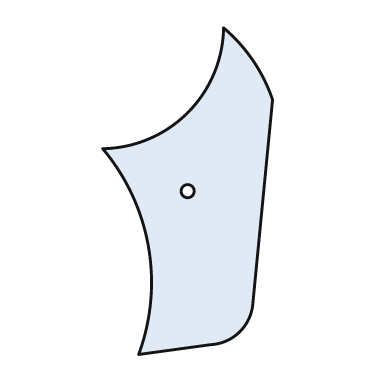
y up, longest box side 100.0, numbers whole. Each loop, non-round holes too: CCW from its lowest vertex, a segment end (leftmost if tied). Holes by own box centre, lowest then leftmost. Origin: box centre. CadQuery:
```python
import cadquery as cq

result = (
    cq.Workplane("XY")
    .moveTo(-15.0, -50.0)
    .lineTo(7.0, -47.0)
    .threePointArc((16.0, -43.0), (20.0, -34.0))
    .lineTo(26.0, 28.0)
    .threePointArc((20.0, 40.0), (11.0, 50.0))
    .threePointArc((0.0, 24.0), (-26.0, 13.0))
    .threePointArc((-12.0, -17.0), (-15.0, -50.0))
    .close()
    .moveTo(0.0, 0.0)
    .circle(2.0)
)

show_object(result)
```